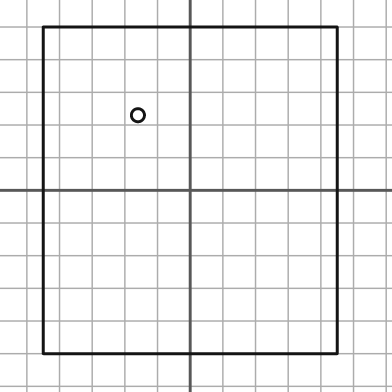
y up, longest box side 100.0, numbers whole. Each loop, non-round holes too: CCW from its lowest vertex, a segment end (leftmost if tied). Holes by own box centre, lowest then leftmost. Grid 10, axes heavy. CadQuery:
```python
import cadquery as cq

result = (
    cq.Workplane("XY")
    .moveTo(-45.0, -50.0)
    .lineTo(45.0, -50.0)
    .lineTo(45.0, 50.0)
    .lineTo(-45.0, 50.0)
    .close()
    .moveTo(-16.0, 23.0)
    .circle(2.0)
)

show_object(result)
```